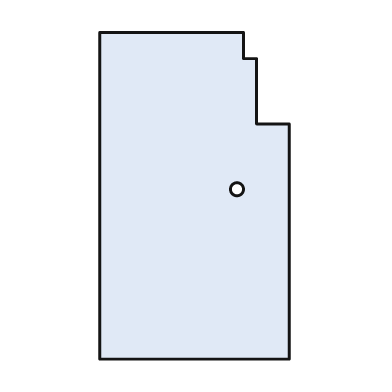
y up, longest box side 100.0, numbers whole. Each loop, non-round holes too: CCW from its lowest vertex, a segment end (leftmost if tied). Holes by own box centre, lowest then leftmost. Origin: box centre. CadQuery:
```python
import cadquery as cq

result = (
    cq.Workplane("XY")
    .moveTo(-29.0, -50.0)
    .lineTo(29.0, -50.0)
    .lineTo(29.0, 22.0)
    .lineTo(19.0, 22.0)
    .lineTo(19.0, 42.0)
    .lineTo(15.0, 42.0)
    .lineTo(15.0, 50.0)
    .lineTo(-29.0, 50.0)
    .close()
    .moveTo(13.0, 2.0)
    .circle(2.0)
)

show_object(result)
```